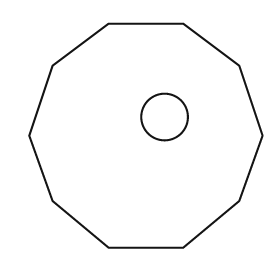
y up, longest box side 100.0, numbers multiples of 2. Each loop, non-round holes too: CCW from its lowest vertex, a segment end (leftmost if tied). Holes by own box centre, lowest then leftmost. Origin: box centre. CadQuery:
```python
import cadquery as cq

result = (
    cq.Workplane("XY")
    .moveTo(-16.0, -48.0)
    .lineTo(16.0, -48.0)
    .lineTo(40.0, -28.0)
    .lineTo(50.0, 0.0)
    .lineTo(40.0, 30.0)
    .lineTo(16.0, 48.0)
    .lineTo(-16.0, 48.0)
    .lineTo(-40.0, 30.0)
    .lineTo(-50.0, 0.0)
    .lineTo(-40.0, -28.0)
    .close()
    .moveTo(8.0, 8.0)
    .circle(10.0)
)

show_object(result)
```